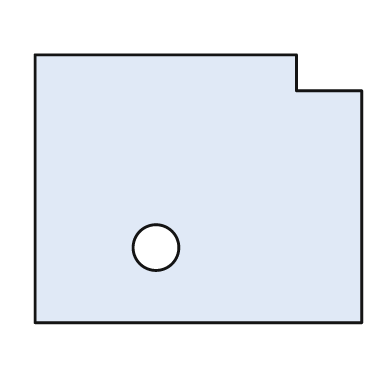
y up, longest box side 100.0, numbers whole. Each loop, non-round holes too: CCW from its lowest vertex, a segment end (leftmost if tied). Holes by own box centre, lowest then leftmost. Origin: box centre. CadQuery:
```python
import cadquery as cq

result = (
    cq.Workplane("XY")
    .moveTo(-50.0, -41.0)
    .lineTo(50.0, -41.0)
    .lineTo(50.0, 30.0)
    .lineTo(30.0, 30.0)
    .lineTo(30.0, 41.0)
    .lineTo(-50.0, 41.0)
    .close()
    .moveTo(-13.0, -18.0)
    .circle(7.0)
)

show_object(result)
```